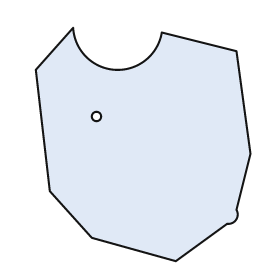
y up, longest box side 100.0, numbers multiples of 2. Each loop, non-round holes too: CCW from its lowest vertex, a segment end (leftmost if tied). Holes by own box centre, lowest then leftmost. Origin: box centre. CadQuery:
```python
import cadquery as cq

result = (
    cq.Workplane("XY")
    .moveTo(14.0, -50.0)
    .lineTo(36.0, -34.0)
    .threePointArc((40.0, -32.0), (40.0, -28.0))
    .lineTo(46.0, -4.0)
    .lineTo(40.0, 40.0)
    .lineTo(8.0, 48.0)
    .threePointArc((-12.0, 32.0), (-30.0, 50.0))
    .lineTo(-46.0, 32.0)
    .lineTo(-40.0, -20.0)
    .lineTo(-22.0, -40.0)
    .close()
    .moveTo(-20.0, 12.0)
    .circle(2.0)
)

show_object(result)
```